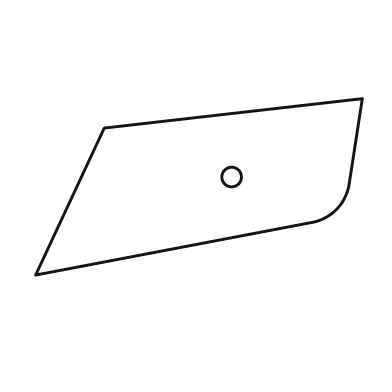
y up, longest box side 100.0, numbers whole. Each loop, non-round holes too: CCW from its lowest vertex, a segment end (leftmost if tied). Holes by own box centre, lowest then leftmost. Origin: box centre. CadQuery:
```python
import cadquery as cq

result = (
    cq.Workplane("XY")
    .moveTo(-50.0, -27.0)
    .lineTo(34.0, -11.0)
    .threePointArc((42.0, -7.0), (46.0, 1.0))
    .lineTo(50.0, 27.0)
    .lineTo(-29.0, 18.0)
    .close()
    .moveTo(10.0, 3.0)
    .circle(3.0)
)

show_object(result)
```